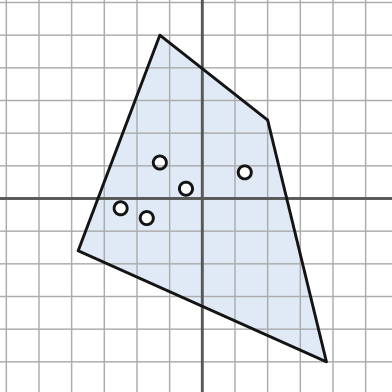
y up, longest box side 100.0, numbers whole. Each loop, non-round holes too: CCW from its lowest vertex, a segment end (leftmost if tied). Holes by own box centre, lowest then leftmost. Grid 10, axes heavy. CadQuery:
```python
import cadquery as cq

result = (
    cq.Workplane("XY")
    .moveTo(38.0, -50.0)
    .lineTo(20.0, 24.0)
    .lineTo(-13.0, 50.0)
    .lineTo(-38.0, -16.0)
    .close()
    .moveTo(-17.0, -6.0)
    .circle(2.0)
    .moveTo(-25.0, -3.0)
    .circle(2.0)
    .moveTo(-5.0, 3.0)
    .circle(2.0)
    .moveTo(13.0, 8.0)
    .circle(2.0)
    .moveTo(-13.0, 11.0)
    .circle(2.0)
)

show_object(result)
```